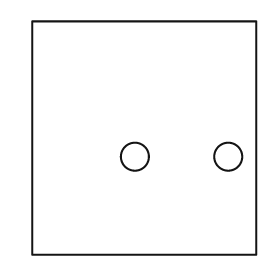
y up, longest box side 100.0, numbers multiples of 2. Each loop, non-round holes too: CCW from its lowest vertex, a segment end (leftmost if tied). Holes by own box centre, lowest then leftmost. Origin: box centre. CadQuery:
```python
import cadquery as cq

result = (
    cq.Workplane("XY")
    .moveTo(-48.0, -50.0)
    .lineTo(48.0, -50.0)
    .lineTo(48.0, 50.0)
    .lineTo(-48.0, 50.0)
    .close()
    .moveTo(-4.0, -8.0)
    .circle(6.0)
    .moveTo(36.0, -8.0)
    .circle(6.0)
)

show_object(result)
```